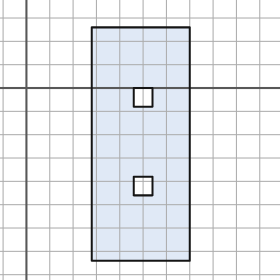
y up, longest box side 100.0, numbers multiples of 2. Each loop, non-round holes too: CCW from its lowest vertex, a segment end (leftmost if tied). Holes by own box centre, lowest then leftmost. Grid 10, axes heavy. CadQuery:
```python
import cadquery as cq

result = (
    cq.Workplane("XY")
    .moveTo(28.0, -74.0)
    .lineTo(70.0, -74.0)
    .lineTo(70.0, 26.0)
    .lineTo(28.0, 26.0)
    .close()
    .moveTo(46.0, -46.0)
    .lineTo(54.0, -46.0)
    .lineTo(54.0, -38.0)
    .lineTo(46.0, -38.0)
    .close()
    .moveTo(46.0, -8.0)
    .lineTo(54.0, -8.0)
    .lineTo(54.0, 0.0)
    .lineTo(46.0, 0.0)
    .close()
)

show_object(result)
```